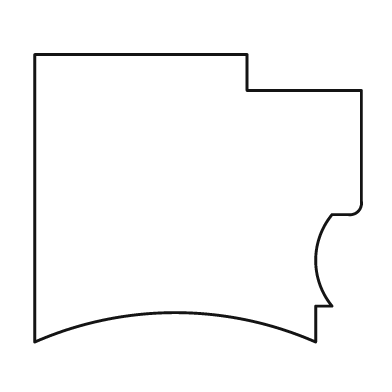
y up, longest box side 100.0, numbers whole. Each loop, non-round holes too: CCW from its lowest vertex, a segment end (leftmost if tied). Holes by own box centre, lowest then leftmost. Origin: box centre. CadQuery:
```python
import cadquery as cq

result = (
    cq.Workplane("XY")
    .moveTo(-50.0, -44.0)
    .threePointArc((-7.0, -35.0), (36.0, -44.0))
    .lineTo(36.0, -33.0)
    .lineTo(41.0, -33.0)
    .threePointArc((36.0, -19.0), (41.0, -5.0))
    .lineTo(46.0, -5.0)
    .threePointArc((49.0, -4.0), (50.0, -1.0))
    .lineTo(50.0, 33.0)
    .lineTo(15.0, 33.0)
    .lineTo(15.0, 44.0)
    .lineTo(-50.0, 44.0)
    .close()
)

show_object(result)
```